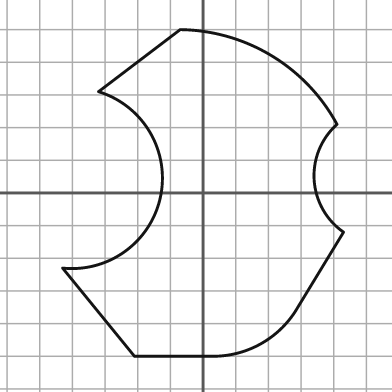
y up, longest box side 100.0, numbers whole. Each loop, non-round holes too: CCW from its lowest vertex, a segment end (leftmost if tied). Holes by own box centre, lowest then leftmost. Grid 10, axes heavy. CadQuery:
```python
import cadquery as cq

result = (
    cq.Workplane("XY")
    .moveTo(-21.0, -50.0)
    .lineTo(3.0, -50.0)
    .threePointArc((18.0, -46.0), (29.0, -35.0))
    .lineTo(43.0, -12.0)
    .threePointArc((34.0, 4.0), (41.0, 21.0))
    .threePointArc((21.0, 42.0), (-7.0, 50.0))
    .lineTo(-32.0, 31.0)
    .threePointArc((-13.0, -1.0), (-43.0, -23.0))
    .close()
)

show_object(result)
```